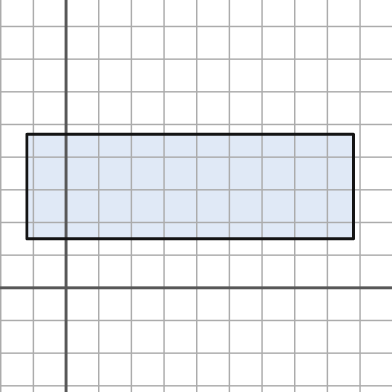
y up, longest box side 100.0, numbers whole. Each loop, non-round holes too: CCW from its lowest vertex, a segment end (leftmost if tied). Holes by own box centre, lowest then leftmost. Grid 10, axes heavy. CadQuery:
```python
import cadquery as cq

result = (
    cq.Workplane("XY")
    .moveTo(-12.0, 15.0)
    .lineTo(88.0, 15.0)
    .lineTo(88.0, 47.0)
    .lineTo(-12.0, 47.0)
    .close()
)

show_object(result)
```